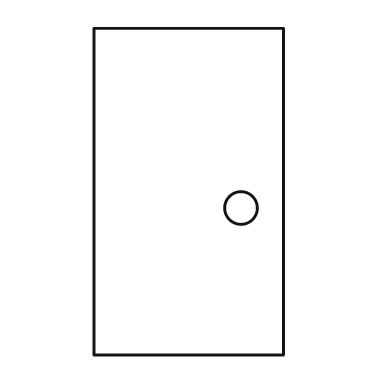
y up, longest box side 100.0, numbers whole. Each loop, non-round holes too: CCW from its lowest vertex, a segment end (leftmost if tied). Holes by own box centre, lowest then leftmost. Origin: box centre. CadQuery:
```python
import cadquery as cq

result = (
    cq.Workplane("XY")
    .moveTo(-29.0, -50.0)
    .lineTo(29.0, -50.0)
    .lineTo(29.0, 50.0)
    .lineTo(-29.0, 50.0)
    .close()
    .moveTo(16.0, -5.0)
    .circle(5.0)
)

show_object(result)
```